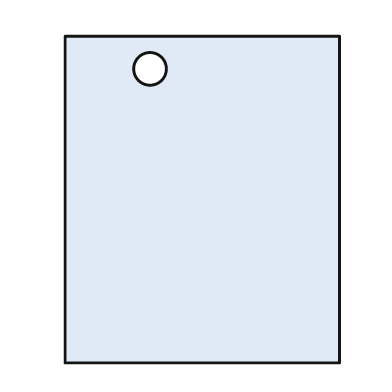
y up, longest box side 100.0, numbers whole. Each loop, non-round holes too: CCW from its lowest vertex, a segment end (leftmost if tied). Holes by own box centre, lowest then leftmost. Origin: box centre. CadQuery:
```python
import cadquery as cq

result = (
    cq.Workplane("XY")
    .moveTo(-42.0, -50.0)
    .lineTo(42.0, -50.0)
    .lineTo(42.0, 50.0)
    .lineTo(-42.0, 50.0)
    .close()
    .moveTo(-16.0, 40.0)
    .circle(5.0)
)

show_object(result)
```